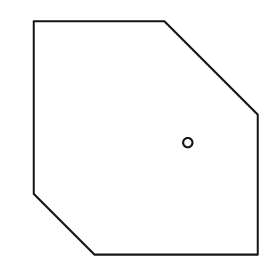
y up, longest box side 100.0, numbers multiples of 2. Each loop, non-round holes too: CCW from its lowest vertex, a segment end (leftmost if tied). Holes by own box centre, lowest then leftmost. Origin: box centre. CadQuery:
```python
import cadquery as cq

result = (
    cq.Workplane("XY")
    .moveTo(-22.0, -50.0)
    .lineTo(48.0, -50.0)
    .lineTo(48.0, 10.0)
    .lineTo(8.0, 50.0)
    .lineTo(-48.0, 50.0)
    .lineTo(-48.0, -24.0)
    .close()
    .moveTo(18.0, -2.0)
    .circle(2.0)
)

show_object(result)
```